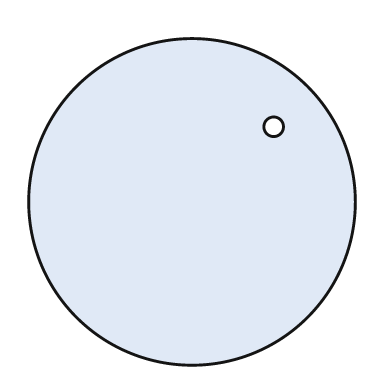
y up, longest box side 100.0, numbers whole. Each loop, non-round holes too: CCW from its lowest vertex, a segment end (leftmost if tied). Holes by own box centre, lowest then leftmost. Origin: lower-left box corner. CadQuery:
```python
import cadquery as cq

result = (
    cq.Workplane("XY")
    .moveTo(50.0, 50.0)
    .circle(50.0)
    .moveTo(75.0, 73.0)
    .circle(3.0)
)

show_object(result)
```